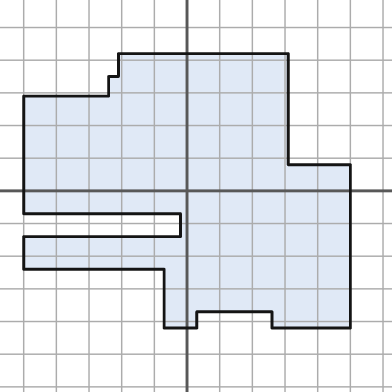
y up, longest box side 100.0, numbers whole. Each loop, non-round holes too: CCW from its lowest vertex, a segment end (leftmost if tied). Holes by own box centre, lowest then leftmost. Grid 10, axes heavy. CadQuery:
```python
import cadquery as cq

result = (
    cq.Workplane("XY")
    .moveTo(-7.0, -42.0)
    .lineTo(3.0, -42.0)
    .lineTo(3.0, -37.0)
    .lineTo(26.0, -37.0)
    .lineTo(26.0, -42.0)
    .lineTo(50.0, -42.0)
    .lineTo(50.0, 8.0)
    .lineTo(31.0, 8.0)
    .lineTo(31.0, 42.0)
    .lineTo(-21.0, 42.0)
    .lineTo(-21.0, 35.0)
    .lineTo(-24.0, 35.0)
    .lineTo(-24.0, 29.0)
    .lineTo(-50.0, 29.0)
    .lineTo(-50.0, -7.0)
    .lineTo(-2.0, -7.0)
    .lineTo(-2.0, -14.0)
    .lineTo(-50.0, -14.0)
    .lineTo(-50.0, -24.0)
    .lineTo(-7.0, -24.0)
    .close()
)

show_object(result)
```